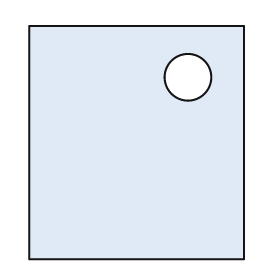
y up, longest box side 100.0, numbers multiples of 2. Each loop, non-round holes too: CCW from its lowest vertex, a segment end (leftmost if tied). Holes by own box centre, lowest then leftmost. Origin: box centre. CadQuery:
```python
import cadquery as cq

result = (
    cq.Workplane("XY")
    .moveTo(-46.0, -50.0)
    .lineTo(46.0, -50.0)
    .lineTo(46.0, 50.0)
    .lineTo(-46.0, 50.0)
    .close()
    .moveTo(22.0, 28.0)
    .circle(10.0)
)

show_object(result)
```